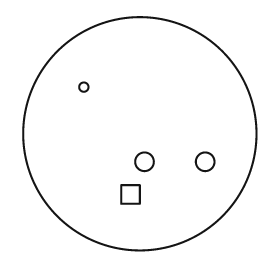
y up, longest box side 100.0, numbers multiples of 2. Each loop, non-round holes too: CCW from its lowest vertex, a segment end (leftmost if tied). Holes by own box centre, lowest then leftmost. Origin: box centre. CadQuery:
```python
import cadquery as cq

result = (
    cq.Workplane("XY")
    .moveTo(0.0, 0.0)
    .circle(50.0)
    .moveTo(-8.0, -30.0)
    .lineTo(0.0, -30.0)
    .lineTo(0.0, -22.0)
    .lineTo(-8.0, -22.0)
    .close()
    .moveTo(2.0, -12.0)
    .circle(4.0)
    .moveTo(28.0, -12.0)
    .circle(4.0)
    .moveTo(-24.0, 20.0)
    .circle(2.0)
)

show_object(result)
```